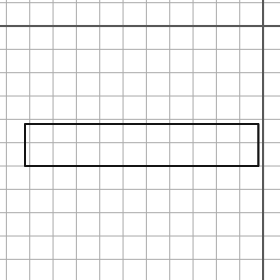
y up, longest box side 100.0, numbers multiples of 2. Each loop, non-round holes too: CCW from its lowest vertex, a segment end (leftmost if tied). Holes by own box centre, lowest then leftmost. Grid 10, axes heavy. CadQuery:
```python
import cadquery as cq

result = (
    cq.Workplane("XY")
    .moveTo(-102.0, -60.0)
    .lineTo(-2.0, -60.0)
    .lineTo(-2.0, -42.0)
    .lineTo(-102.0, -42.0)
    .close()
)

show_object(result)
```